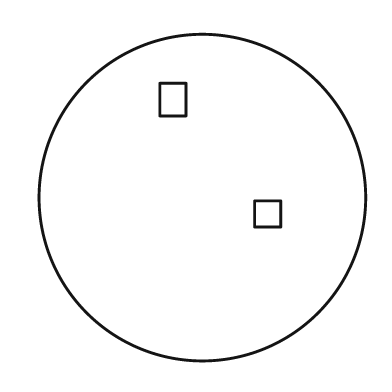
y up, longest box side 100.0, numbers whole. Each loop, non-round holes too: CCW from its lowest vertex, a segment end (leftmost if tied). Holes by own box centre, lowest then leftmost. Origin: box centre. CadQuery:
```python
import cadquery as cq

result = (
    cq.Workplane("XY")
    .moveTo(0.0, 0.0)
    .circle(50.0)
    .moveTo(16.0, -9.0)
    .lineTo(24.0, -9.0)
    .lineTo(24.0, -1.0)
    .lineTo(16.0, -1.0)
    .close()
    .moveTo(-13.0, 25.0)
    .lineTo(-5.0, 25.0)
    .lineTo(-5.0, 35.0)
    .lineTo(-13.0, 35.0)
    .close()
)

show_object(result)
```